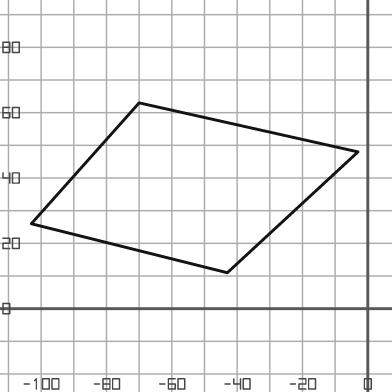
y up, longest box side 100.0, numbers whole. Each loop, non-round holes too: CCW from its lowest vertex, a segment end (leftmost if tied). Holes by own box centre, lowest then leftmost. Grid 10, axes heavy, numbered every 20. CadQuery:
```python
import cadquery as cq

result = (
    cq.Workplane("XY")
    .moveTo(-43.0, 11.0)
    .lineTo(-3.0, 48.0)
    .lineTo(-70.0, 63.0)
    .lineTo(-103.0, 26.0)
    .close()
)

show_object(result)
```